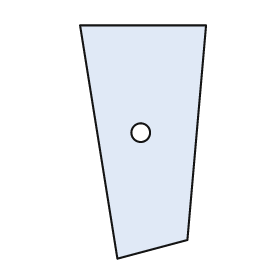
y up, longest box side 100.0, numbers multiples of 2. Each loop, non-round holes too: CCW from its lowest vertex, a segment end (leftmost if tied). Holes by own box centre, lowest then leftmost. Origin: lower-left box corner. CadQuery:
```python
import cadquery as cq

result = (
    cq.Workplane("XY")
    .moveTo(16.0, 0.0)
    .lineTo(46.0, 8.0)
    .lineTo(54.0, 100.0)
    .lineTo(0.0, 100.0)
    .close()
    .moveTo(26.0, 54.0)
    .circle(4.0)
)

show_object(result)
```